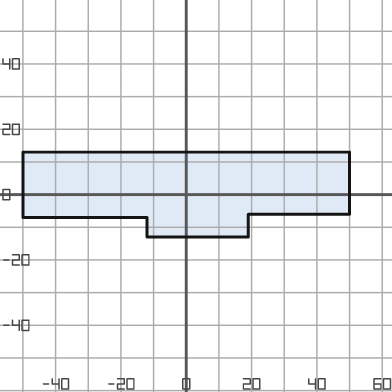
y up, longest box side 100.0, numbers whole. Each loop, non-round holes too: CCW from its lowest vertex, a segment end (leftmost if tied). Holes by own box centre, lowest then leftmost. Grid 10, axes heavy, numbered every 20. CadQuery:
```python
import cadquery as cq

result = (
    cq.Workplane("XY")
    .moveTo(-12.0, -13.0)
    .lineTo(19.0, -13.0)
    .lineTo(19.0, -6.0)
    .lineTo(50.0, -6.0)
    .lineTo(50.0, 13.0)
    .lineTo(-50.0, 13.0)
    .lineTo(-50.0, -7.0)
    .lineTo(-12.0, -7.0)
    .close()
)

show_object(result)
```